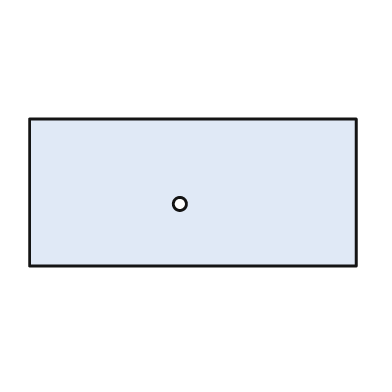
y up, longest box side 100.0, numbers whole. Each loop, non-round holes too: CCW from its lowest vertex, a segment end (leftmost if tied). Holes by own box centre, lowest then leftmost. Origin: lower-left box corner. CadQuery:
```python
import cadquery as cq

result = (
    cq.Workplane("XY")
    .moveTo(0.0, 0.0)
    .lineTo(100.0, 0.0)
    .lineTo(100.0, 45.0)
    .lineTo(0.0, 45.0)
    .close()
    .moveTo(46.0, 19.0)
    .circle(2.0)
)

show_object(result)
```